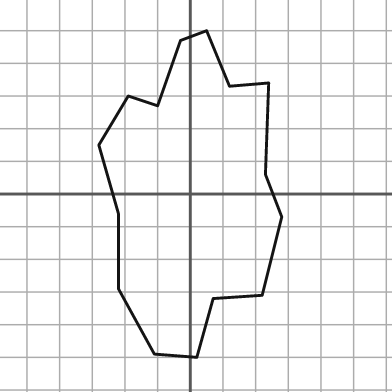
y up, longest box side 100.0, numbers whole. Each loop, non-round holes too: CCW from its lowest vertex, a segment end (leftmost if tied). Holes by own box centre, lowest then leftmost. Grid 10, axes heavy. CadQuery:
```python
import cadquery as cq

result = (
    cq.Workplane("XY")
    .moveTo(2.0, -50.0)
    .lineTo(7.0, -32.0)
    .lineTo(22.0, -31.0)
    .lineTo(28.0, -7.0)
    .lineTo(23.0, 6.0)
    .lineTo(24.0, 34.0)
    .lineTo(12.0, 33.0)
    .lineTo(5.0, 50.0)
    .lineTo(-3.0, 47.0)
    .lineTo(-10.0, 27.0)
    .lineTo(-19.0, 30.0)
    .lineTo(-28.0, 15.0)
    .lineTo(-22.0, -6.0)
    .lineTo(-22.0, -29.0)
    .lineTo(-11.0, -49.0)
    .close()
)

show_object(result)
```